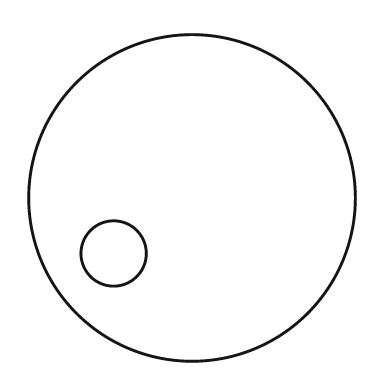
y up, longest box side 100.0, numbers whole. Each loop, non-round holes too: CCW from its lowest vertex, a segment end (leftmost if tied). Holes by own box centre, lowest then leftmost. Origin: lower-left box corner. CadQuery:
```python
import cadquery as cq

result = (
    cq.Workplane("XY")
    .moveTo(50.0, 50.0)
    .circle(50.0)
    .moveTo(26.0, 33.0)
    .circle(10.0)
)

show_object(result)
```